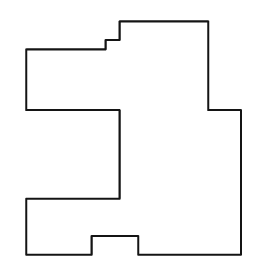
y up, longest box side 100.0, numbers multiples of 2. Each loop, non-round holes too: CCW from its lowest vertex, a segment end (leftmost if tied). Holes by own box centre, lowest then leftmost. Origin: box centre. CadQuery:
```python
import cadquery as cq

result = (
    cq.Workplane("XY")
    .moveTo(-46.0, -50.0)
    .lineTo(-18.0, -50.0)
    .lineTo(-18.0, -42.0)
    .lineTo(2.0, -42.0)
    .lineTo(2.0, -50.0)
    .lineTo(46.0, -50.0)
    .lineTo(46.0, 12.0)
    .lineTo(32.0, 12.0)
    .lineTo(32.0, 50.0)
    .lineTo(-6.0, 50.0)
    .lineTo(-6.0, 42.0)
    .lineTo(-12.0, 42.0)
    .lineTo(-12.0, 38.0)
    .lineTo(-46.0, 38.0)
    .lineTo(-46.0, 12.0)
    .lineTo(-6.0, 12.0)
    .lineTo(-6.0, -26.0)
    .lineTo(-46.0, -26.0)
    .close()
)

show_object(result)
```